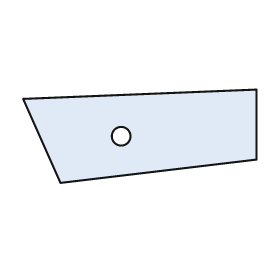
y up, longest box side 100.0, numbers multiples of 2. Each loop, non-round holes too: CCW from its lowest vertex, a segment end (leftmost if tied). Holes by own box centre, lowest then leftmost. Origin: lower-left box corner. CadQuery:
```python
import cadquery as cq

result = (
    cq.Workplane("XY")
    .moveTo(16.0, 0.0)
    .lineTo(100.0, 10.0)
    .lineTo(100.0, 40.0)
    .lineTo(0.0, 36.0)
    .close()
    .moveTo(42.0, 20.0)
    .circle(4.0)
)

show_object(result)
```